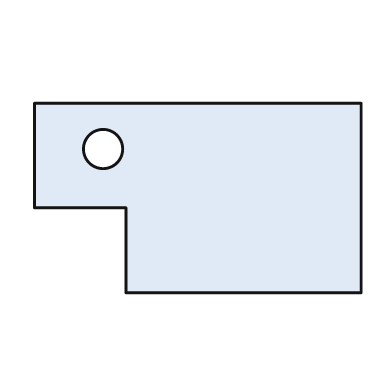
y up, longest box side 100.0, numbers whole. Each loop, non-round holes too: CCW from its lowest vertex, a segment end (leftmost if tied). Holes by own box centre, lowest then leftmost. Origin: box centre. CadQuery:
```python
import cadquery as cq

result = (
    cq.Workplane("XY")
    .moveTo(-22.0, -29.0)
    .lineTo(50.0, -29.0)
    .lineTo(50.0, 29.0)
    .lineTo(-50.0, 29.0)
    .lineTo(-50.0, -3.0)
    .lineTo(-22.0, -3.0)
    .close()
    .moveTo(-29.0, 15.0)
    .circle(6.0)
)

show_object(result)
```